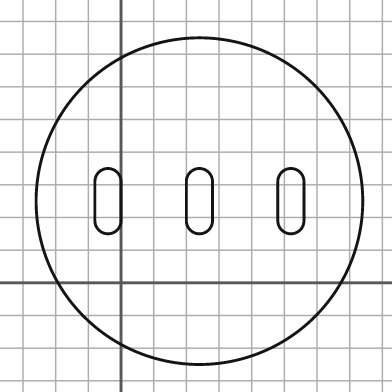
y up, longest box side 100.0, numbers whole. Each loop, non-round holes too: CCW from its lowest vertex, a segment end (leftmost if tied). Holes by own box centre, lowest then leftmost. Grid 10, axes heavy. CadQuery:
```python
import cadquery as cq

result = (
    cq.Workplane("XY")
    .moveTo(24.0, 25.0)
    .circle(50.0)
    .moveTo(-8.0, 19.0)
    .threePointArc((-4.0, 15.0), (0.0, 19.0))
    .lineTo(0.0, 31.0)
    .threePointArc((-4.0, 35.0), (-8.0, 31.0))
    .close()
    .moveTo(20.0, 19.0)
    .threePointArc((24.0, 15.0), (28.0, 19.0))
    .lineTo(28.0, 31.0)
    .threePointArc((24.0, 35.0), (20.0, 31.0))
    .close()
    .moveTo(48.0, 19.0)
    .threePointArc((52.0, 15.0), (56.0, 19.0))
    .lineTo(56.0, 31.0)
    .threePointArc((52.0, 35.0), (48.0, 31.0))
    .close()
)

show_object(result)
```